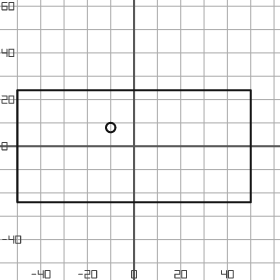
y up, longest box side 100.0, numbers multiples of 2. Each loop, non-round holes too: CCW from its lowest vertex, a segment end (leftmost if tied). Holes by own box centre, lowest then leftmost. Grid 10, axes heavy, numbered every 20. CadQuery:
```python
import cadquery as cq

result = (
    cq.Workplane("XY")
    .moveTo(-50.0, -24.0)
    .lineTo(50.0, -24.0)
    .lineTo(50.0, 24.0)
    .lineTo(-50.0, 24.0)
    .close()
    .moveTo(-10.0, 8.0)
    .circle(2.0)
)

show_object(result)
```